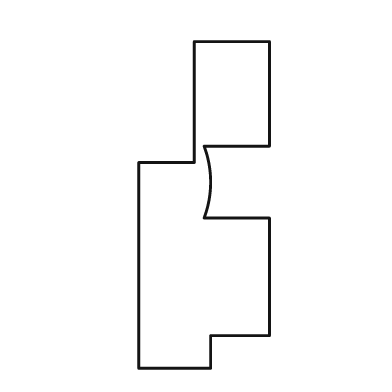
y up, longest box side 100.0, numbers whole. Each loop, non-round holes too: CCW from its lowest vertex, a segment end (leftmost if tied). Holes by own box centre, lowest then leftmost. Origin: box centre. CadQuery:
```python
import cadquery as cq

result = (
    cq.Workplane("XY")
    .moveTo(-20.0, -50.0)
    .lineTo(2.0, -50.0)
    .lineTo(2.0, -40.0)
    .lineTo(20.0, -40.0)
    .lineTo(20.0, -4.0)
    .lineTo(0.0, -4.0)
    .threePointArc((2.0, 7.0), (0.0, 18.0))
    .lineTo(20.0, 18.0)
    .lineTo(20.0, 50.0)
    .lineTo(-3.0, 50.0)
    .lineTo(-3.0, 13.0)
    .lineTo(-20.0, 13.0)
    .close()
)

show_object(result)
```